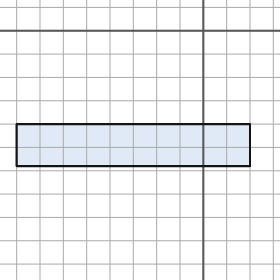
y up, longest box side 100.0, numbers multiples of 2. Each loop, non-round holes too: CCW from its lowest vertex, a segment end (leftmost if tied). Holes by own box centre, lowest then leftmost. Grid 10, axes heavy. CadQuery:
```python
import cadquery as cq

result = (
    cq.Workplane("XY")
    .moveTo(-80.0, -58.0)
    .lineTo(20.0, -58.0)
    .lineTo(20.0, -40.0)
    .lineTo(-80.0, -40.0)
    .close()
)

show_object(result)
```